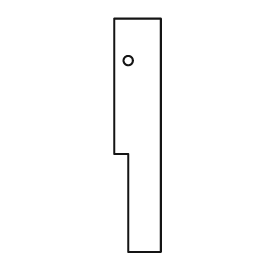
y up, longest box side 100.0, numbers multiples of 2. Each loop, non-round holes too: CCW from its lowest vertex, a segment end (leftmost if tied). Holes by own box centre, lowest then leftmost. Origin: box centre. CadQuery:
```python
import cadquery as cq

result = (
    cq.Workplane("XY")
    .moveTo(-4.0, -50.0)
    .lineTo(10.0, -50.0)
    .lineTo(10.0, 50.0)
    .lineTo(-10.0, 50.0)
    .lineTo(-10.0, -8.0)
    .lineTo(-4.0, -8.0)
    .close()
    .moveTo(-4.0, 32.0)
    .circle(2.0)
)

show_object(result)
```